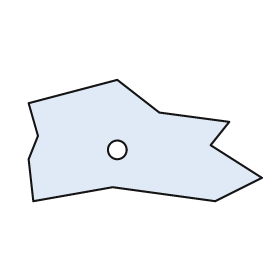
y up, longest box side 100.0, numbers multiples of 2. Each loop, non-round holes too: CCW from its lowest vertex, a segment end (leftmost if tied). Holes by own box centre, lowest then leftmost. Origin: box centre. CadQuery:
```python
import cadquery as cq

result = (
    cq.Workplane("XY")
    .moveTo(-48.0, -26.0)
    .lineTo(-14.0, -20.0)
    .lineTo(30.0, -26.0)
    .lineTo(50.0, -16.0)
    .lineTo(28.0, -2.0)
    .lineTo(36.0, 8.0)
    .lineTo(6.0, 12.0)
    .lineTo(-12.0, 26.0)
    .lineTo(-50.0, 16.0)
    .lineTo(-46.0, 2.0)
    .lineTo(-50.0, -8.0)
    .close()
    .moveTo(-12.0, -4.0)
    .circle(4.0)
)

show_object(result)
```